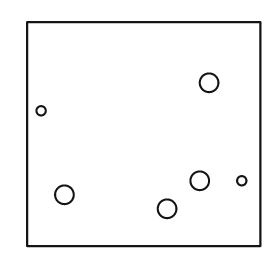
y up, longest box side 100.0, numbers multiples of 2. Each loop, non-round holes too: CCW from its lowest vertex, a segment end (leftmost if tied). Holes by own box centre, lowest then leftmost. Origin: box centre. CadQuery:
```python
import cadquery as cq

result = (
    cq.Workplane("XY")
    .moveTo(-50.0, -48.0)
    .lineTo(50.0, -48.0)
    .lineTo(50.0, 48.0)
    .lineTo(-50.0, 48.0)
    .close()
    .moveTo(10.0, -32.0)
    .circle(4.0)
    .moveTo(-34.0, -26.0)
    .circle(4.0)
    .moveTo(24.0, -20.0)
    .circle(4.0)
    .moveTo(42.0, -20.0)
    .circle(2.0)
    .moveTo(-44.0, 10.0)
    .circle(2.0)
    .moveTo(28.0, 22.0)
    .circle(4.0)
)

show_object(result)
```